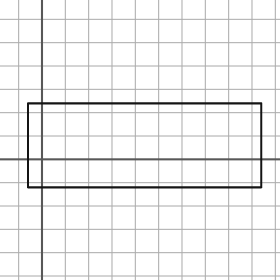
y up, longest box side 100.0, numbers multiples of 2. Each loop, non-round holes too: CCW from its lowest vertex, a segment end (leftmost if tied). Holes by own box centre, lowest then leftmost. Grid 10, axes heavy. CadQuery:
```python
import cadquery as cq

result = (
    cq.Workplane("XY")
    .moveTo(-6.0, -12.0)
    .lineTo(94.0, -12.0)
    .lineTo(94.0, 24.0)
    .lineTo(-6.0, 24.0)
    .close()
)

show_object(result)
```